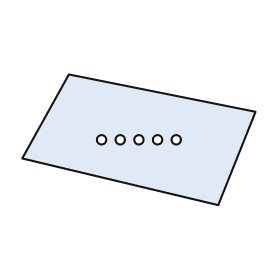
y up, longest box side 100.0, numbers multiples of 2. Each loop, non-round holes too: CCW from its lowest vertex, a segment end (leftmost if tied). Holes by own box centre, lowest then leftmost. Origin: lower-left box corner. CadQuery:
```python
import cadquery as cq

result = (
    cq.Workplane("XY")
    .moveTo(84.0, 0.0)
    .lineTo(100.0, 40.0)
    .lineTo(20.0, 56.0)
    .lineTo(0.0, 20.0)
    .close()
    .moveTo(34.0, 28.0)
    .circle(2.0)
    .moveTo(42.0, 28.0)
    .circle(2.0)
    .moveTo(50.0, 28.0)
    .circle(2.0)
    .moveTo(58.0, 28.0)
    .circle(2.0)
    .moveTo(66.0, 28.0)
    .circle(2.0)
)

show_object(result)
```